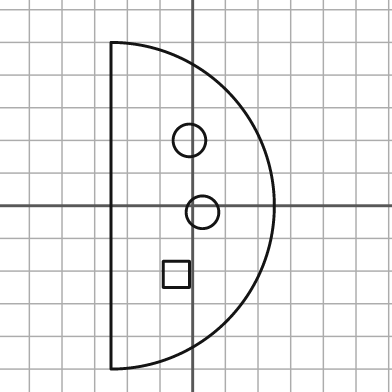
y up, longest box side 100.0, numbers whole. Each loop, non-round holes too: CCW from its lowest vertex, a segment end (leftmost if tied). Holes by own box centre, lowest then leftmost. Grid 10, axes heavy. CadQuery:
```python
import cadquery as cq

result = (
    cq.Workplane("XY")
    .moveTo(-25.0, -50.0)
    .threePointArc((25.0, 0.0), (-25.0, 50.0))
    .close()
    .moveTo(-9.0, -25.0)
    .lineTo(-1.0, -25.0)
    .lineTo(-1.0, -17.0)
    .lineTo(-9.0, -17.0)
    .close()
    .moveTo(3.0, -2.0)
    .circle(5.0)
    .moveTo(-1.0, 20.0)
    .circle(5.0)
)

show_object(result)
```